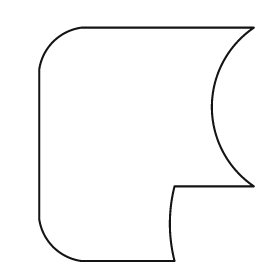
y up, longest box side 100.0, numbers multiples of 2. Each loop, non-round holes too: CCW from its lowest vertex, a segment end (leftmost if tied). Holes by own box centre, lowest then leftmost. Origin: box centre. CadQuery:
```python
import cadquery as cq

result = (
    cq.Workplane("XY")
    .moveTo(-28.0, -50.0)
    .lineTo(12.0, -50.0)
    .threePointArc((10.0, -34.0), (12.0, -18.0))
    .lineTo(46.0, -18.0)
    .threePointArc((28.0, 16.0), (46.0, 50.0))
    .lineTo(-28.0, 50.0)
    .threePointArc((-40.0, 44.0), (-46.0, 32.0))
    .lineTo(-46.0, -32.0)
    .threePointArc((-40.0, -44.0), (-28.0, -50.0))
    .close()
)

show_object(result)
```